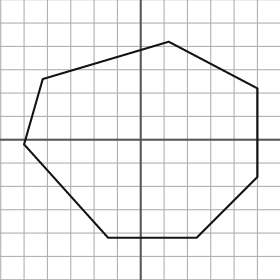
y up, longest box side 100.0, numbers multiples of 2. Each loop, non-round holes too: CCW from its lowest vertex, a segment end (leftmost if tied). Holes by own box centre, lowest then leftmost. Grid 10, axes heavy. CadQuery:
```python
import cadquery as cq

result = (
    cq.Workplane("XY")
    .moveTo(-14.0, -42.0)
    .lineTo(24.0, -42.0)
    .lineTo(50.0, -16.0)
    .lineTo(50.0, 22.0)
    .lineTo(12.0, 42.0)
    .lineTo(-42.0, 26.0)
    .lineTo(-50.0, -2.0)
    .close()
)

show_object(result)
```